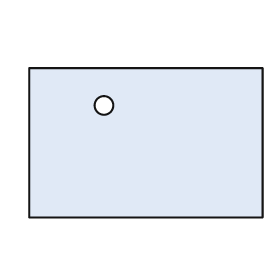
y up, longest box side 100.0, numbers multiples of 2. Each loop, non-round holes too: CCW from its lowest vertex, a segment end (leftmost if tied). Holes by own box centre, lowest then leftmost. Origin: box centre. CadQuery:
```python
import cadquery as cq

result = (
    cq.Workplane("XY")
    .moveTo(-50.0, -32.0)
    .lineTo(50.0, -32.0)
    .lineTo(50.0, 32.0)
    .lineTo(-50.0, 32.0)
    .close()
    .moveTo(-18.0, 16.0)
    .circle(4.0)
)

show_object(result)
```